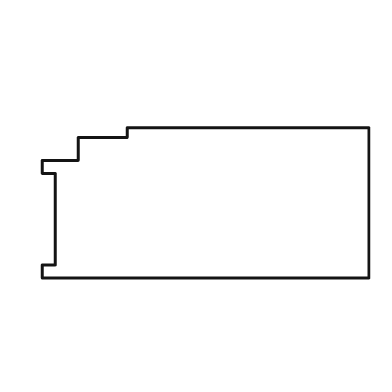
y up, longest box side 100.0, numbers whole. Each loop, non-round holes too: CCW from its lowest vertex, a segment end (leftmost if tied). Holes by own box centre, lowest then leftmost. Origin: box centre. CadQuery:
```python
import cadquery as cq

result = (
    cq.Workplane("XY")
    .moveTo(-50.0, -23.0)
    .lineTo(50.0, -23.0)
    .lineTo(50.0, 23.0)
    .lineTo(-24.0, 23.0)
    .lineTo(-24.0, 20.0)
    .lineTo(-39.0, 20.0)
    .lineTo(-39.0, 13.0)
    .lineTo(-50.0, 13.0)
    .lineTo(-50.0, 9.0)
    .lineTo(-46.0, 9.0)
    .lineTo(-46.0, -19.0)
    .lineTo(-50.0, -19.0)
    .close()
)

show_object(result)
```